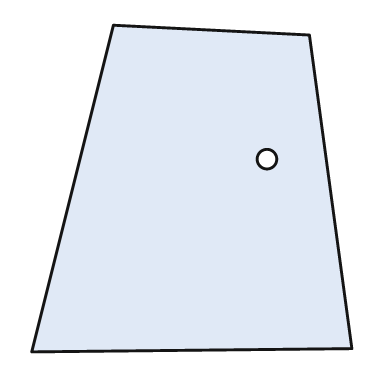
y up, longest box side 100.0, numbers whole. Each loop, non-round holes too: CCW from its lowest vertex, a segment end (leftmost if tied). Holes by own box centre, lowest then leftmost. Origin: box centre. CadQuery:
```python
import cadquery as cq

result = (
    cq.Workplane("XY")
    .moveTo(-49.0, -50.0)
    .lineTo(49.0, -49.0)
    .lineTo(36.0, 47.0)
    .lineTo(-24.0, 50.0)
    .close()
    .moveTo(23.0, 9.0)
    .circle(3.0)
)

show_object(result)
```